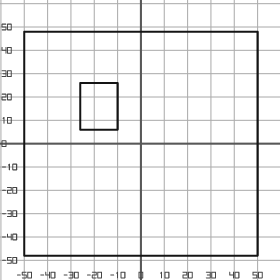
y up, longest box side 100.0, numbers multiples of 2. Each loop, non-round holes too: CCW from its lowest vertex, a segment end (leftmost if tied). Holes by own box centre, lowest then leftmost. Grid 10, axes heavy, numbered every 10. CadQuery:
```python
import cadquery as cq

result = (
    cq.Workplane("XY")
    .moveTo(-50.0, -48.0)
    .lineTo(50.0, -48.0)
    .lineTo(50.0, 48.0)
    .lineTo(-50.0, 48.0)
    .close()
    .moveTo(-26.0, 6.0)
    .lineTo(-10.0, 6.0)
    .lineTo(-10.0, 26.0)
    .lineTo(-26.0, 26.0)
    .close()
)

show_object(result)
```